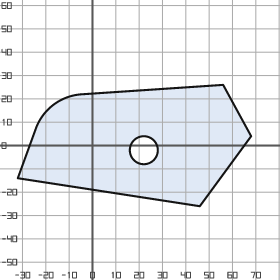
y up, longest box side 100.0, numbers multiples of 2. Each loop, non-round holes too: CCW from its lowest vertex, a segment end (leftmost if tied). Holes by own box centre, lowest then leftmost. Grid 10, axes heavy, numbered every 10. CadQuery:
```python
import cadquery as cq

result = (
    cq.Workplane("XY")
    .moveTo(46.0, -26.0)
    .lineTo(68.0, 4.0)
    .lineTo(56.0, 26.0)
    .lineTo(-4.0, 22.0)
    .threePointArc((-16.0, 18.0), (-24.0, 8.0))
    .lineTo(-32.0, -14.0)
    .close()
    .moveTo(22.0, -2.0)
    .circle(6.0)
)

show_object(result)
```